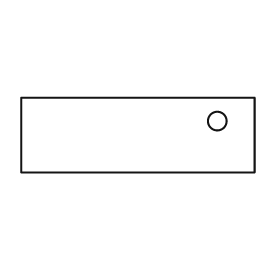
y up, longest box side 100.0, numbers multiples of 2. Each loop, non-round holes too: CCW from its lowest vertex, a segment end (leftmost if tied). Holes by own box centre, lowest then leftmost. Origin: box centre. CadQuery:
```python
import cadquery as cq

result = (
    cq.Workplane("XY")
    .moveTo(-50.0, -16.0)
    .lineTo(50.0, -16.0)
    .lineTo(50.0, 16.0)
    .lineTo(-50.0, 16.0)
    .close()
    .moveTo(34.0, 6.0)
    .circle(4.0)
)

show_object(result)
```